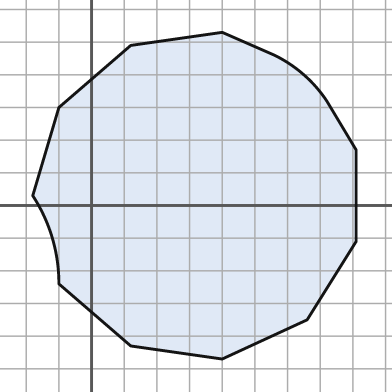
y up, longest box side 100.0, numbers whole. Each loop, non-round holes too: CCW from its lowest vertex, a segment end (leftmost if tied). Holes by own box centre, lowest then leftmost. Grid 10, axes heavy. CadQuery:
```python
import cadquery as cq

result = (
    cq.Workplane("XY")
    .moveTo(40.0, -47.0)
    .lineTo(66.0, -35.0)
    .lineTo(81.0, -11.0)
    .lineTo(81.0, 17.0)
    .lineTo(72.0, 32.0)
    .threePointArc((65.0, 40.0), (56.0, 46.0))
    .lineTo(40.0, 53.0)
    .lineTo(12.0, 49.0)
    .lineTo(-10.0, 30.0)
    .lineTo(-18.0, 3.0)
    .threePointArc((-12.0, -10.0), (-10.0, -24.0))
    .lineTo(12.0, -43.0)
    .close()
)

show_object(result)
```